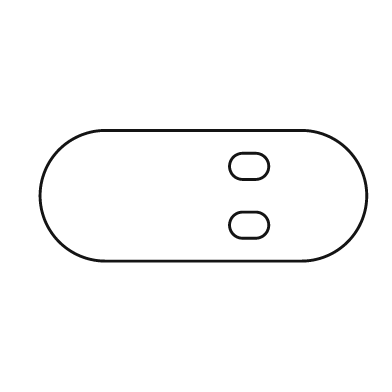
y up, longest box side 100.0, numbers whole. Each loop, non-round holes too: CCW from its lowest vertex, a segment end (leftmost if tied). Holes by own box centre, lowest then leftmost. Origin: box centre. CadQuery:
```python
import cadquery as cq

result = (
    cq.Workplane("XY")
    .moveTo(-30.0, -20.0)
    .lineTo(30.0, -20.0)
    .threePointArc((50.0, 0.0), (30.0, 20.0))
    .lineTo(-30.0, 20.0)
    .threePointArc((-50.0, 0.0), (-30.0, -20.0))
    .close()
    .moveTo(12.0, -13.0)
    .lineTo(16.0, -13.0)
    .threePointArc((20.0, -9.0), (16.0, -5.0))
    .lineTo(12.0, -5.0)
    .threePointArc((8.0, -9.0), (12.0, -13.0))
    .close()
    .moveTo(12.0, 5.0)
    .lineTo(16.0, 5.0)
    .threePointArc((20.0, 9.0), (16.0, 13.0))
    .lineTo(12.0, 13.0)
    .threePointArc((8.0, 9.0), (12.0, 5.0))
    .close()
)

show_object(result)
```